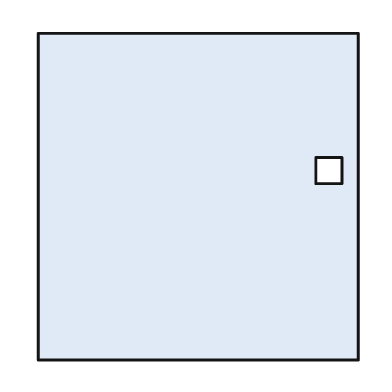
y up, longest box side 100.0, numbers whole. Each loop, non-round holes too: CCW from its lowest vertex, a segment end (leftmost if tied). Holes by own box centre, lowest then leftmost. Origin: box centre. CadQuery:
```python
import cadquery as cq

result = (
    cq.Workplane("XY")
    .moveTo(-49.0, -50.0)
    .lineTo(49.0, -50.0)
    .lineTo(49.0, 50.0)
    .lineTo(-49.0, 50.0)
    .close()
    .moveTo(36.0, 4.0)
    .lineTo(44.0, 4.0)
    .lineTo(44.0, 12.0)
    .lineTo(36.0, 12.0)
    .close()
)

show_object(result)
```